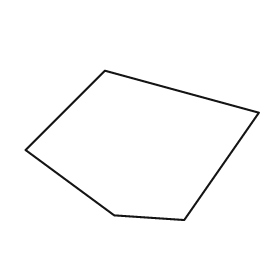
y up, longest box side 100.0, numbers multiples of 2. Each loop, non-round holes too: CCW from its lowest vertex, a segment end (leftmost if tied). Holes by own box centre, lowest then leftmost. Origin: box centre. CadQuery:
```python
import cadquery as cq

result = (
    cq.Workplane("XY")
    .moveTo(18.0, -32.0)
    .lineTo(50.0, 14.0)
    .lineTo(-16.0, 32.0)
    .lineTo(-50.0, -2.0)
    .lineTo(-12.0, -30.0)
    .close()
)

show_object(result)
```